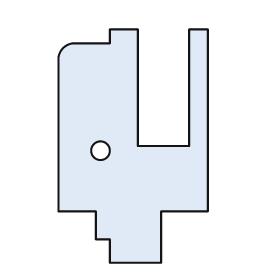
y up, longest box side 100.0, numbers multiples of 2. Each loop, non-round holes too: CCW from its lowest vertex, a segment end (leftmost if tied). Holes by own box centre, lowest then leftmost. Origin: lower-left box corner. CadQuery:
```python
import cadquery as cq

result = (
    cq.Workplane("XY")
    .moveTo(22.0, 0.0)
    .lineTo(44.0, 0.0)
    .lineTo(44.0, 22.0)
    .lineTo(64.0, 22.0)
    .lineTo(64.0, 100.0)
    .lineTo(56.0, 100.0)
    .lineTo(56.0, 50.0)
    .lineTo(34.0, 50.0)
    .lineTo(34.0, 100.0)
    .lineTo(22.0, 100.0)
    .lineTo(22.0, 94.0)
    .lineTo(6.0, 94.0)
    .threePointArc((2.0, 92.0), (0.0, 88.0))
    .lineTo(0.0, 22.0)
    .lineTo(16.0, 22.0)
    .lineTo(16.0, 10.0)
    .lineTo(22.0, 10.0)
    .close()
    .moveTo(18.0, 48.0)
    .circle(4.0)
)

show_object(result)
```